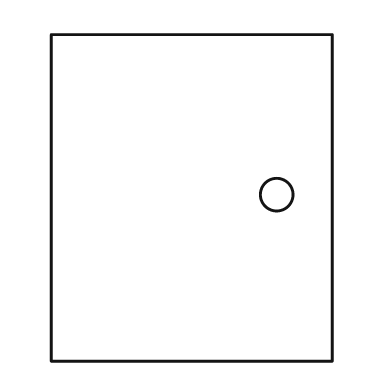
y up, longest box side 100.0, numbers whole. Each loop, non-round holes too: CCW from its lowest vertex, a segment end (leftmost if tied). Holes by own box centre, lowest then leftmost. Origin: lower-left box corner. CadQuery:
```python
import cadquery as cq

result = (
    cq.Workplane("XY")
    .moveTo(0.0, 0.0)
    .lineTo(86.0, 0.0)
    .lineTo(86.0, 100.0)
    .lineTo(0.0, 100.0)
    .close()
    .moveTo(69.0, 51.0)
    .circle(5.0)
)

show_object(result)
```